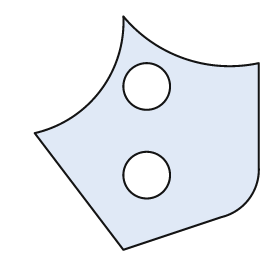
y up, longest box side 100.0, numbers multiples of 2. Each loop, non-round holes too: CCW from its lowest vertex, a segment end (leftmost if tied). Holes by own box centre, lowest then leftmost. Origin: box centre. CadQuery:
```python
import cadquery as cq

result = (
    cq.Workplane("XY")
    .moveTo(-10.0, -50.0)
    .lineTo(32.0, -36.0)
    .threePointArc((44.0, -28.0), (48.0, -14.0))
    .lineTo(48.0, 30.0)
    .threePointArc((16.0, 32.0), (-10.0, 50.0))
    .threePointArc((-20.0, 18.0), (-48.0, 0.0))
    .close()
    .moveTo(0.0, -18.0)
    .circle(10.0)
    .moveTo(0.0, 20.0)
    .circle(10.0)
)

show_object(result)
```